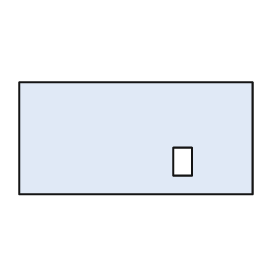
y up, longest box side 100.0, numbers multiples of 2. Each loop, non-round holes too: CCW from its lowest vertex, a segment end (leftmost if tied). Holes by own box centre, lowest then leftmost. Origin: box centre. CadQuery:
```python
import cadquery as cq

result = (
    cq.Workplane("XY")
    .moveTo(-50.0, -24.0)
    .lineTo(50.0, -24.0)
    .lineTo(50.0, 24.0)
    .lineTo(-50.0, 24.0)
    .close()
    .moveTo(16.0, -16.0)
    .lineTo(24.0, -16.0)
    .lineTo(24.0, -4.0)
    .lineTo(16.0, -4.0)
    .close()
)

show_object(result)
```